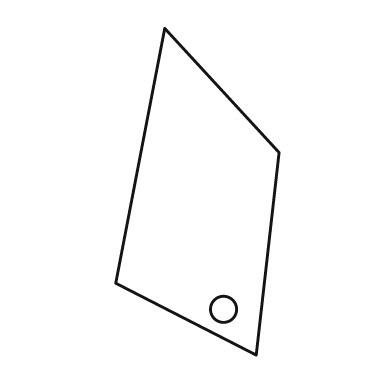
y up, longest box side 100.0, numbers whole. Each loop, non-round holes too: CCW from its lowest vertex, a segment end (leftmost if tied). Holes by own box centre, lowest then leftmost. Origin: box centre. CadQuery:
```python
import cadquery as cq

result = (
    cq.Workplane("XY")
    .moveTo(18.0, -50.0)
    .lineTo(25.0, 12.0)
    .lineTo(-10.0, 50.0)
    .lineTo(-25.0, -28.0)
    .close()
    .moveTo(8.0, -36.0)
    .circle(4.0)
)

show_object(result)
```